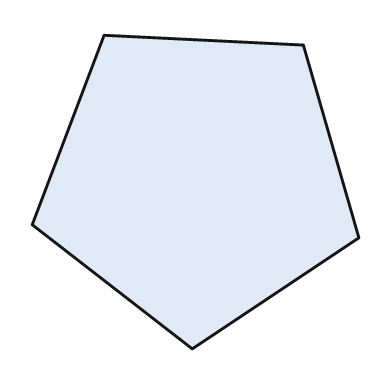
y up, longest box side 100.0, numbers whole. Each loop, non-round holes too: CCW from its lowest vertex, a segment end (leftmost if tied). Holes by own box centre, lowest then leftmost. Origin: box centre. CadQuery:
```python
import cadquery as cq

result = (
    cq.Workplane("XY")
    .moveTo(-1.0, -48.0)
    .lineTo(50.0, -14.0)
    .lineTo(33.0, 45.0)
    .lineTo(-28.0, 48.0)
    .lineTo(-50.0, -10.0)
    .close()
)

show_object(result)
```